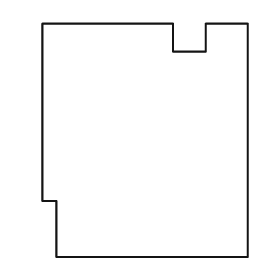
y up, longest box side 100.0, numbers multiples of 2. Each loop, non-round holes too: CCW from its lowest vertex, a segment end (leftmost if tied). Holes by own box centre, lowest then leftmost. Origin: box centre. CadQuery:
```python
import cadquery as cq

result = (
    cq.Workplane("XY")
    .moveTo(-38.0, -50.0)
    .lineTo(44.0, -50.0)
    .lineTo(44.0, 50.0)
    .lineTo(26.0, 50.0)
    .lineTo(26.0, 38.0)
    .lineTo(12.0, 38.0)
    .lineTo(12.0, 50.0)
    .lineTo(-44.0, 50.0)
    .lineTo(-44.0, -26.0)
    .lineTo(-38.0, -26.0)
    .close()
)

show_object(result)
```